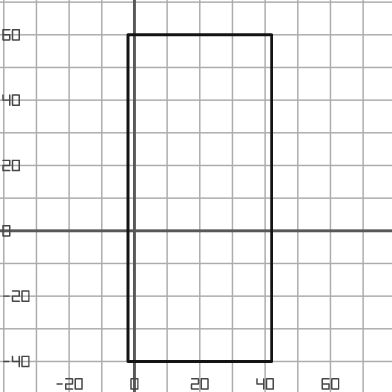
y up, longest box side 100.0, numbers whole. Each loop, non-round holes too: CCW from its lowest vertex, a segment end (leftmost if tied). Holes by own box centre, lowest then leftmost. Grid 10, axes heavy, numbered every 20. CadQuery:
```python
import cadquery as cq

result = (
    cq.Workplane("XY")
    .moveTo(-2.0, -40.0)
    .lineTo(42.0, -40.0)
    .lineTo(42.0, 60.0)
    .lineTo(-2.0, 60.0)
    .close()
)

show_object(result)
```